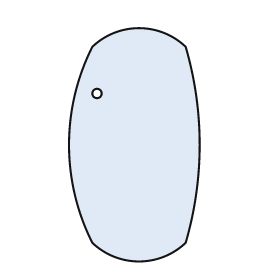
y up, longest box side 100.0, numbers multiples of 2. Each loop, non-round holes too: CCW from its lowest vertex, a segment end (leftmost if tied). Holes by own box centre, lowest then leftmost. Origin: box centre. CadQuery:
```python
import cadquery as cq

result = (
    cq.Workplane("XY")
    .moveTo(-18.0, -42.0)
    .threePointArc((2.0, -50.0), (22.0, -42.0))
    .threePointArc((28.0, 0.0), (22.0, 42.0))
    .threePointArc((2.0, 50.0), (-18.0, 42.0))
    .threePointArc((-28.0, 0.0), (-18.0, -42.0))
    .close()
    .moveTo(-16.0, 22.0)
    .circle(2.0)
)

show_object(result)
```